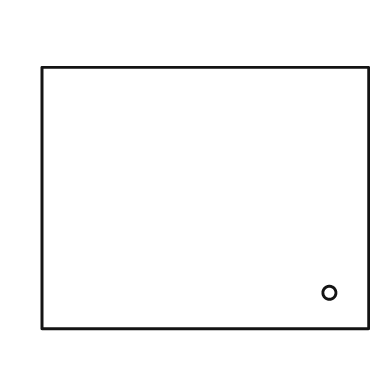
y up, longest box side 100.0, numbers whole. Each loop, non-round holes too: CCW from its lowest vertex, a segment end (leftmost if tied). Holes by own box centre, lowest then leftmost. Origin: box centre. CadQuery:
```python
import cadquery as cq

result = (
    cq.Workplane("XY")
    .moveTo(-50.0, -40.0)
    .lineTo(50.0, -40.0)
    .lineTo(50.0, 40.0)
    .lineTo(-50.0, 40.0)
    .close()
    .moveTo(38.0, -29.0)
    .circle(2.0)
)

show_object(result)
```